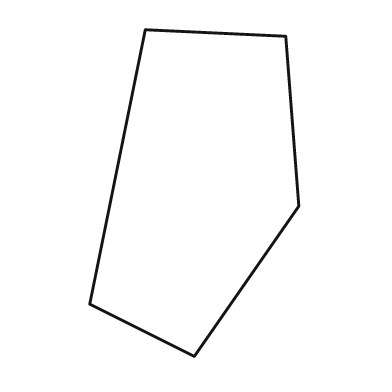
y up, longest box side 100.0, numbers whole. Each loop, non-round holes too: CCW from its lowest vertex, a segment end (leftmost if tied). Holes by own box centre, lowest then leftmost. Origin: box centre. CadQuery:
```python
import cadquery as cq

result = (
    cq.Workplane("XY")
    .moveTo(0.0, -50.0)
    .lineTo(32.0, -4.0)
    .lineTo(28.0, 48.0)
    .lineTo(-15.0, 50.0)
    .lineTo(-32.0, -34.0)
    .close()
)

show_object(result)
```